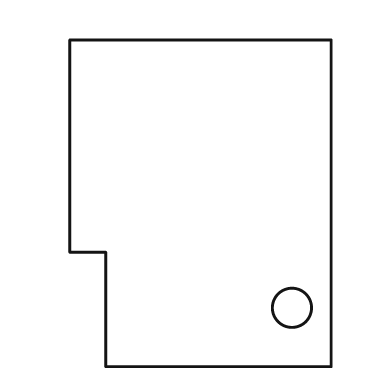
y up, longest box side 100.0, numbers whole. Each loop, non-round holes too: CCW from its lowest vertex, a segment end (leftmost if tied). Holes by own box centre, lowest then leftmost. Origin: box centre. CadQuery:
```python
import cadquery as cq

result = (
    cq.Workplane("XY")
    .moveTo(-29.0, -50.0)
    .lineTo(40.0, -50.0)
    .lineTo(40.0, 50.0)
    .lineTo(-40.0, 50.0)
    .lineTo(-40.0, -15.0)
    .lineTo(-29.0, -15.0)
    .close()
    .moveTo(28.0, -32.0)
    .circle(6.0)
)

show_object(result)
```